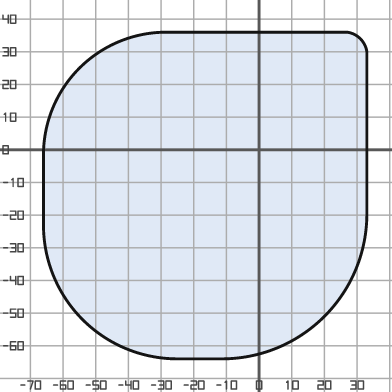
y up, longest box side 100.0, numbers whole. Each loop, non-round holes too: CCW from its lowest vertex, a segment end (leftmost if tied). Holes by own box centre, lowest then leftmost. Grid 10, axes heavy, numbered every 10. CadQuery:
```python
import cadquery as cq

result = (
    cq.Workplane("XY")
    .moveTo(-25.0, -64.0)
    .lineTo(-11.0, -64.0)
    .threePointArc((20.0, -51.0), (33.0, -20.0))
    .lineTo(33.0, 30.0)
    .threePointArc((31.0, 34.0), (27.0, 36.0))
    .lineTo(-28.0, 36.0)
    .threePointArc((-55.0, 25.0), (-66.0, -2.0))
    .lineTo(-66.0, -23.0)
    .threePointArc((-54.0, -52.0), (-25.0, -64.0))
    .close()
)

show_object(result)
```